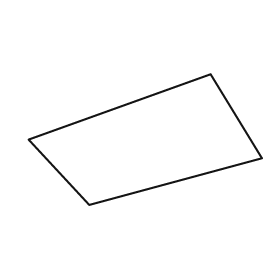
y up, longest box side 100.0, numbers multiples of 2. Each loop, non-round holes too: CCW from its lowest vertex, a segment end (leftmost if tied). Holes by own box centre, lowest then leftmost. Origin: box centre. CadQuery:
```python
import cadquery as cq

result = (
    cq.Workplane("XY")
    .moveTo(-24.0, -28.0)
    .lineTo(50.0, -8.0)
    .lineTo(28.0, 28.0)
    .lineTo(-50.0, 0.0)
    .close()
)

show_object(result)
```